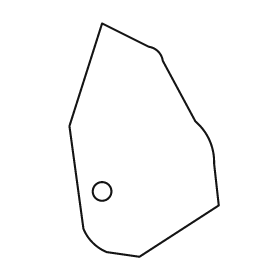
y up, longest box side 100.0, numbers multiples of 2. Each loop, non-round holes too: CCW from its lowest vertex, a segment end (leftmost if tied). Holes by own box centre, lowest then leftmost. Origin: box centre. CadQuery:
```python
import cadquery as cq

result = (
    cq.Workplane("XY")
    .moveTo(-2.0, -50.0)
    .lineTo(32.0, -28.0)
    .lineTo(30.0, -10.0)
    .threePointArc((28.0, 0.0), (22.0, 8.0))
    .lineTo(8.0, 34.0)
    .threePointArc((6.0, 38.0), (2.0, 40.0))
    .lineTo(-18.0, 50.0)
    .lineTo(-32.0, 6.0)
    .lineTo(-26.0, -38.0)
    .threePointArc((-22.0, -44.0), (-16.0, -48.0))
    .close()
    .moveTo(-18.0, -22.0)
    .circle(4.0)
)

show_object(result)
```